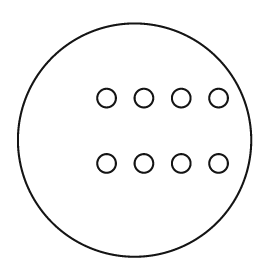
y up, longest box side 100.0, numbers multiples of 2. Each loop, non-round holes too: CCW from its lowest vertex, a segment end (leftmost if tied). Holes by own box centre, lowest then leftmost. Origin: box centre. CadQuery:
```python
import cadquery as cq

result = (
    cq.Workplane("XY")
    .moveTo(0.0, 0.0)
    .circle(50.0)
    .moveTo(-12.0, -10.0)
    .circle(4.0)
    .moveTo(4.0, -10.0)
    .circle(4.0)
    .moveTo(20.0, -10.0)
    .circle(4.0)
    .moveTo(36.0, -10.0)
    .circle(4.0)
    .moveTo(-12.0, 18.0)
    .circle(4.0)
    .moveTo(4.0, 18.0)
    .circle(4.0)
    .moveTo(20.0, 18.0)
    .circle(4.0)
    .moveTo(36.0, 18.0)
    .circle(4.0)
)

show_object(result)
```